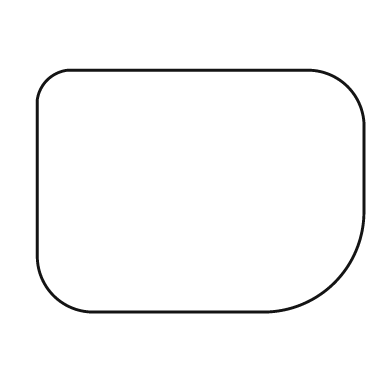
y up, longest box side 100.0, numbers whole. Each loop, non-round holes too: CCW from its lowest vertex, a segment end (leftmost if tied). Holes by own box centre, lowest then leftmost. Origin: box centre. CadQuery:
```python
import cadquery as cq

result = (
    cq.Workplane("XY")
    .moveTo(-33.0, -37.0)
    .lineTo(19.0, -37.0)
    .threePointArc((41.0, -28.0), (50.0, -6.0))
    .lineTo(50.0, 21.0)
    .threePointArc((45.0, 32.0), (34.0, 37.0))
    .lineTo(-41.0, 37.0)
    .threePointArc((-47.0, 34.0), (-50.0, 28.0))
    .lineTo(-50.0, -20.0)
    .threePointArc((-45.0, -32.0), (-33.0, -37.0))
    .close()
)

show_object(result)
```